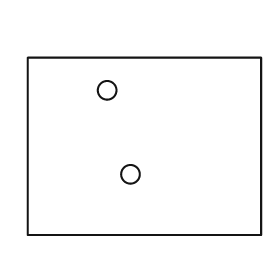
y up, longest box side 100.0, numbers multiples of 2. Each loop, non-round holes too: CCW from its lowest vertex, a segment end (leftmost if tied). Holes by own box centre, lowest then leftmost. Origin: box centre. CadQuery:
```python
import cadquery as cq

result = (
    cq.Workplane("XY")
    .moveTo(-50.0, -38.0)
    .lineTo(50.0, -38.0)
    .lineTo(50.0, 38.0)
    .lineTo(-50.0, 38.0)
    .close()
    .moveTo(-6.0, -12.0)
    .circle(4.0)
    .moveTo(-16.0, 24.0)
    .circle(4.0)
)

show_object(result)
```